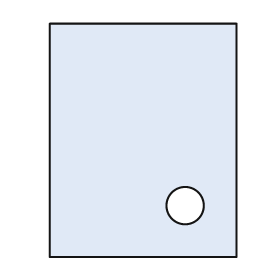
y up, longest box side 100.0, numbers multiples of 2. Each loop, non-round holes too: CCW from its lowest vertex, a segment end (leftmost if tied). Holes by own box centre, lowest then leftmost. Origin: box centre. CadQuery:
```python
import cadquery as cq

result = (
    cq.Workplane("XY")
    .moveTo(-40.0, -50.0)
    .lineTo(40.0, -50.0)
    .lineTo(40.0, 50.0)
    .lineTo(-40.0, 50.0)
    .close()
    .moveTo(18.0, -28.0)
    .circle(8.0)
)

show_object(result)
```